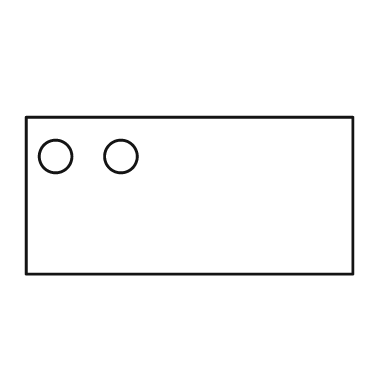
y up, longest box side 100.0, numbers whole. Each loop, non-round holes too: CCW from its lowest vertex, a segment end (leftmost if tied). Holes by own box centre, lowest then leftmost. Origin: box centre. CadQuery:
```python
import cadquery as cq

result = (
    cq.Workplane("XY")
    .moveTo(-50.0, -24.0)
    .lineTo(50.0, -24.0)
    .lineTo(50.0, 24.0)
    .lineTo(-50.0, 24.0)
    .close()
    .moveTo(-41.0, 12.0)
    .circle(5.0)
    .moveTo(-21.0, 12.0)
    .circle(5.0)
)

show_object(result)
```